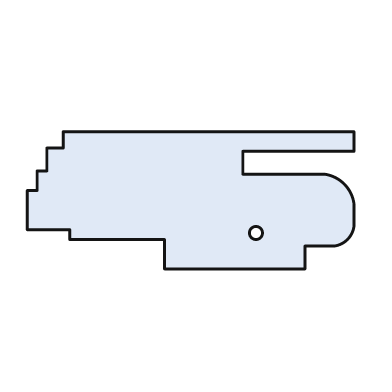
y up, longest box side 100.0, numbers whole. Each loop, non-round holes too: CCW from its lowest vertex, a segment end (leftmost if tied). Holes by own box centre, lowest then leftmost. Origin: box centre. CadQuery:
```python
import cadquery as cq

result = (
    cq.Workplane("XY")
    .moveTo(-8.0, -21.0)
    .lineTo(35.0, -21.0)
    .lineTo(35.0, -14.0)
    .lineTo(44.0, -14.0)
    .threePointArc((48.0, -12.0), (50.0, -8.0))
    .lineTo(50.0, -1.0)
    .threePointArc((47.0, 5.0), (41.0, 8.0))
    .lineTo(16.0, 8.0)
    .lineTo(16.0, 15.0)
    .lineTo(50.0, 15.0)
    .lineTo(50.0, 21.0)
    .lineTo(-39.0, 21.0)
    .lineTo(-39.0, 16.0)
    .lineTo(-44.0, 16.0)
    .lineTo(-44.0, 9.0)
    .lineTo(-47.0, 9.0)
    .lineTo(-47.0, 3.0)
    .lineTo(-50.0, 3.0)
    .lineTo(-50.0, -9.0)
    .lineTo(-37.0, -9.0)
    .lineTo(-37.0, -12.0)
    .lineTo(-8.0, -12.0)
    .close()
    .moveTo(20.0, -10.0)
    .circle(2.0)
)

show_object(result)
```